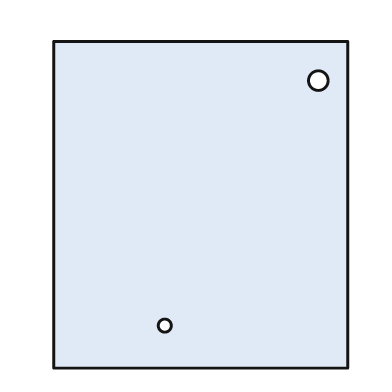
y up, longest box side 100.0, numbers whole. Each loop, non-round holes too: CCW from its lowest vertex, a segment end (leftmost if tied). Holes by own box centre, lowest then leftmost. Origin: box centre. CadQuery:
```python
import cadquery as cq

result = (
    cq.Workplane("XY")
    .moveTo(-45.0, -50.0)
    .lineTo(45.0, -50.0)
    .lineTo(45.0, 50.0)
    .lineTo(-45.0, 50.0)
    .close()
    .moveTo(-11.0, -37.0)
    .circle(2.0)
    .moveTo(36.0, 38.0)
    .circle(3.0)
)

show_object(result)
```